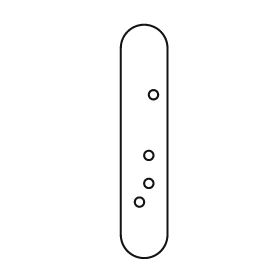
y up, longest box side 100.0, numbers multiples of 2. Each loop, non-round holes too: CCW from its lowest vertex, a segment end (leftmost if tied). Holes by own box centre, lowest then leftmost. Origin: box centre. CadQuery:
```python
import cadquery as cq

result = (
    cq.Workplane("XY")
    .moveTo(-10.0, -40.0)
    .threePointArc((0.0, -50.0), (10.0, -40.0))
    .lineTo(10.0, 40.0)
    .threePointArc((0.0, 50.0), (-10.0, 40.0))
    .close()
    .moveTo(-2.0, -26.0)
    .circle(2.0)
    .moveTo(2.0, -18.0)
    .circle(2.0)
    .moveTo(2.0, -6.0)
    .circle(2.0)
    .moveTo(4.0, 20.0)
    .circle(2.0)
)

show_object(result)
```